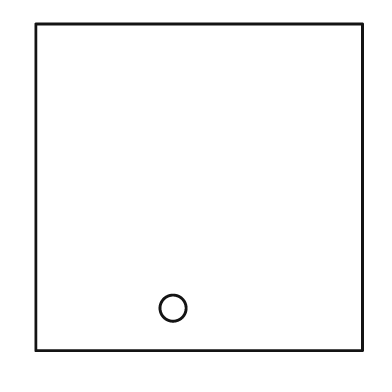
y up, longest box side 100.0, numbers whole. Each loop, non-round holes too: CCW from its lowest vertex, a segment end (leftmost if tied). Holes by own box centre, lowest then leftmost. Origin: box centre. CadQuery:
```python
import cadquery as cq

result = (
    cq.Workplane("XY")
    .moveTo(-50.0, -50.0)
    .lineTo(50.0, -50.0)
    .lineTo(50.0, 50.0)
    .lineTo(-50.0, 50.0)
    .close()
    .moveTo(-8.0, -37.0)
    .circle(4.0)
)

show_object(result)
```